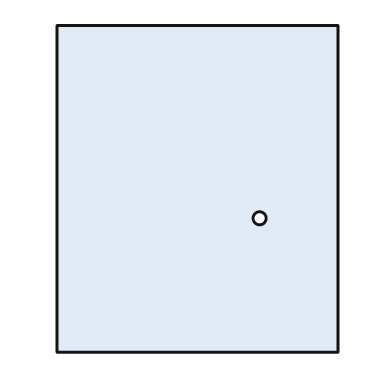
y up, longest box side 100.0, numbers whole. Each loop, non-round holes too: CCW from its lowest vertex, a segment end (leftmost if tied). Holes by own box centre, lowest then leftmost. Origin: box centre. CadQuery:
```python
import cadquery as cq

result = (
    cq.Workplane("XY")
    .moveTo(-43.0, -50.0)
    .lineTo(43.0, -50.0)
    .lineTo(43.0, 50.0)
    .lineTo(-43.0, 50.0)
    .close()
    .moveTo(19.0, -9.0)
    .circle(2.0)
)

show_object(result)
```